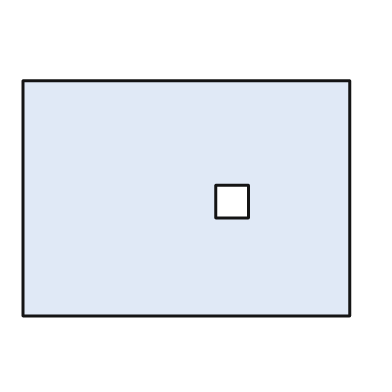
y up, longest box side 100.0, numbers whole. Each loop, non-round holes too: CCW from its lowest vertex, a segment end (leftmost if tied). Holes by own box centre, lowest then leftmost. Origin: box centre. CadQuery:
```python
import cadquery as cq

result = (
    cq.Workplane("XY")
    .moveTo(-50.0, -36.0)
    .lineTo(50.0, -36.0)
    .lineTo(50.0, 36.0)
    .lineTo(-50.0, 36.0)
    .close()
    .moveTo(9.0, -6.0)
    .lineTo(19.0, -6.0)
    .lineTo(19.0, 4.0)
    .lineTo(9.0, 4.0)
    .close()
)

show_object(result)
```